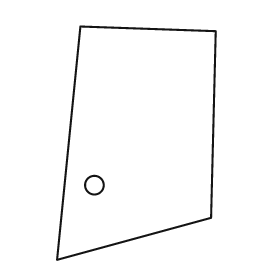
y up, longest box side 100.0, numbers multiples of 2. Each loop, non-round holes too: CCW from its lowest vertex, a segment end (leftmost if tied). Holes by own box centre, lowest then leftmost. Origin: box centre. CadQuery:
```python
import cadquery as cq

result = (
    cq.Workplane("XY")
    .moveTo(-34.0, -50.0)
    .lineTo(32.0, -32.0)
    .lineTo(34.0, 48.0)
    .lineTo(-24.0, 50.0)
    .close()
    .moveTo(-18.0, -18.0)
    .circle(4.0)
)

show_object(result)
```